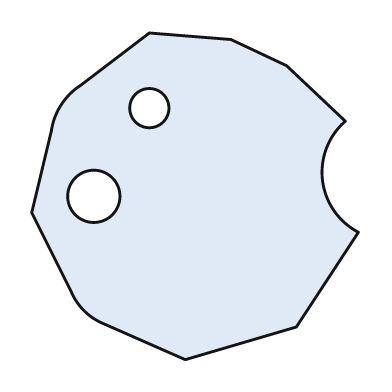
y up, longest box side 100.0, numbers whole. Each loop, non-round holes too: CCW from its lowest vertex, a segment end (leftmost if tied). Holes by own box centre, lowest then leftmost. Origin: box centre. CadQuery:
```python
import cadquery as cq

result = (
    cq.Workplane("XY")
    .moveTo(-3.0, -50.0)
    .lineTo(31.0, -40.0)
    .lineTo(50.0, -11.0)
    .threePointArc((39.0, 5.0), (46.0, 23.0))
    .lineTo(28.0, 40.0)
    .lineTo(11.0, 48.0)
    .lineTo(-14.0, 50.0)
    .lineTo(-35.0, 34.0)
    .threePointArc((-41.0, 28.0), (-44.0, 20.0))
    .lineTo(-50.0, -5.0)
    .lineTo(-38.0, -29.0)
    .threePointArc((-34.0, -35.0), (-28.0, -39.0))
    .close()
    .moveTo(-31.0, 0.0)
    .circle(8.0)
    .moveTo(-14.0, 27.0)
    .circle(6.0)
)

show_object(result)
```